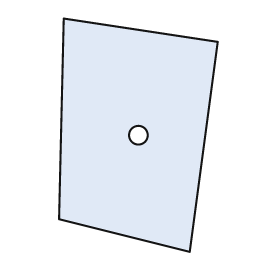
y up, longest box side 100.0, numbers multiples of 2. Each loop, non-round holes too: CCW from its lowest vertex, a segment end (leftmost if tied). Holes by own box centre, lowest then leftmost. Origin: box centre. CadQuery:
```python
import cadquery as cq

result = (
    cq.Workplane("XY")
    .moveTo(22.0, -50.0)
    .lineTo(34.0, 40.0)
    .lineTo(-32.0, 50.0)
    .lineTo(-34.0, -36.0)
    .close()
    .moveTo(0.0, 0.0)
    .circle(4.0)
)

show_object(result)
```